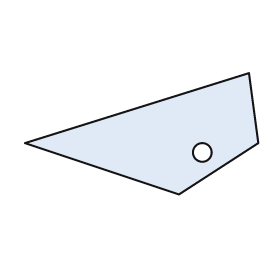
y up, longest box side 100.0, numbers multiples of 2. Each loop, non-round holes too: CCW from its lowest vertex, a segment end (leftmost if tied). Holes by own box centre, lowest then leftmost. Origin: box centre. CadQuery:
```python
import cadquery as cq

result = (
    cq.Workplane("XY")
    .moveTo(16.0, -26.0)
    .lineTo(50.0, -4.0)
    .lineTo(46.0, 26.0)
    .lineTo(-50.0, -4.0)
    .close()
    .moveTo(26.0, -8.0)
    .circle(4.0)
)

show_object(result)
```